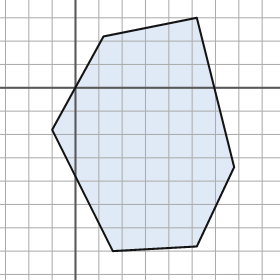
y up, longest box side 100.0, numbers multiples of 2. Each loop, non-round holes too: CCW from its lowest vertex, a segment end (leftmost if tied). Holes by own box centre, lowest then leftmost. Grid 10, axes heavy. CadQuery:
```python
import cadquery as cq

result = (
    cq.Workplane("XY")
    .moveTo(16.0, -70.0)
    .lineTo(52.0, -68.0)
    .lineTo(68.0, -34.0)
    .lineTo(52.0, 30.0)
    .lineTo(12.0, 22.0)
    .lineTo(-10.0, -18.0)
    .close()
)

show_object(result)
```